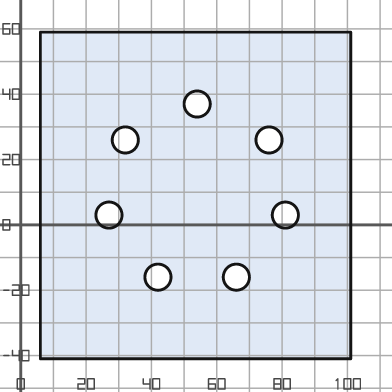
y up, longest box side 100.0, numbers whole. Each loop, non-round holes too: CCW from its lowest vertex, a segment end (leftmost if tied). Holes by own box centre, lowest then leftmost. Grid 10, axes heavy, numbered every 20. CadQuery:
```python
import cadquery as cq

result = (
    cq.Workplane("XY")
    .moveTo(6.0, -41.0)
    .lineTo(101.0, -41.0)
    .lineTo(101.0, 59.0)
    .lineTo(6.0, 59.0)
    .close()
    .moveTo(42.0, -16.0)
    .circle(4.0)
    .moveTo(66.0, -16.0)
    .circle(4.0)
    .moveTo(27.0, 3.0)
    .circle(4.0)
    .moveTo(81.0, 3.0)
    .circle(4.0)
    .moveTo(32.0, 26.0)
    .circle(4.0)
    .moveTo(76.0, 26.0)
    .circle(4.0)
    .moveTo(54.0, 37.0)
    .circle(4.0)
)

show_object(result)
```